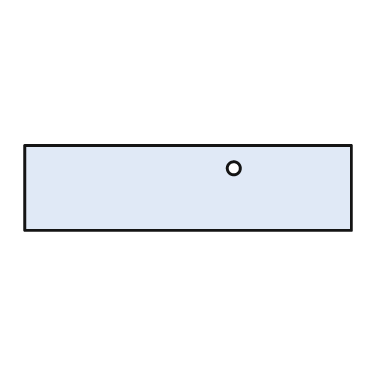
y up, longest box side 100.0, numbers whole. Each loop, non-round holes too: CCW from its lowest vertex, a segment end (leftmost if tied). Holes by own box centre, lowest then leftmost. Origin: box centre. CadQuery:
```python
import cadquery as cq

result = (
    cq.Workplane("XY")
    .moveTo(-50.0, -13.0)
    .lineTo(50.0, -13.0)
    .lineTo(50.0, 13.0)
    .lineTo(-50.0, 13.0)
    .close()
    .moveTo(14.0, 6.0)
    .circle(2.0)
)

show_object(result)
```